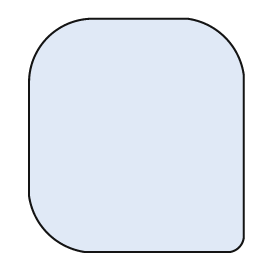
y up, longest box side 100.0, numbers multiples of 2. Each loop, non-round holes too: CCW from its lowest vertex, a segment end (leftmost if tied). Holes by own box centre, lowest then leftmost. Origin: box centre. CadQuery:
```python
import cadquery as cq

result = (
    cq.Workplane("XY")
    .moveTo(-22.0, -50.0)
    .lineTo(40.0, -50.0)
    .threePointArc((44.0, -48.0), (46.0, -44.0))
    .lineTo(46.0, 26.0)
    .threePointArc((38.0, 42.0), (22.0, 50.0))
    .lineTo(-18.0, 50.0)
    .threePointArc((-38.0, 42.0), (-46.0, 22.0))
    .lineTo(-46.0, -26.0)
    .threePointArc((-38.0, -42.0), (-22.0, -50.0))
    .close()
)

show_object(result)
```